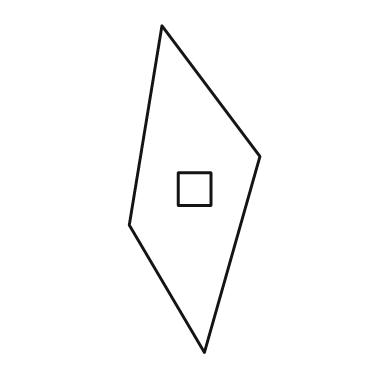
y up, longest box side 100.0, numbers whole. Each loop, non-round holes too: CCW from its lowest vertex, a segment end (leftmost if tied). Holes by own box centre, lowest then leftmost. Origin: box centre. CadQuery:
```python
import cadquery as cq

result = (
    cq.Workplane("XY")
    .moveTo(3.0, -50.0)
    .lineTo(20.0, 10.0)
    .lineTo(-10.0, 50.0)
    .lineTo(-20.0, -11.0)
    .close()
    .moveTo(-5.0, -5.0)
    .lineTo(5.0, -5.0)
    .lineTo(5.0, 5.0)
    .lineTo(-5.0, 5.0)
    .close()
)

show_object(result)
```